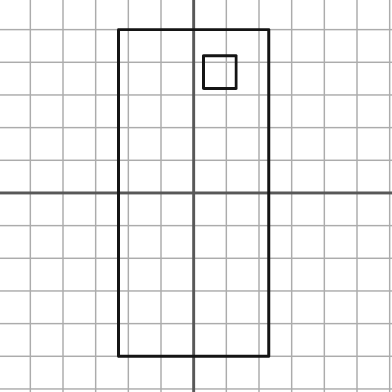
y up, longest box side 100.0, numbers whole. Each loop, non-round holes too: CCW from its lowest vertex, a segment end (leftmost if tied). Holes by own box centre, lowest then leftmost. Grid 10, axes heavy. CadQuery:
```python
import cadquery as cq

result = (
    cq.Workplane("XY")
    .moveTo(-23.0, -50.0)
    .lineTo(23.0, -50.0)
    .lineTo(23.0, 50.0)
    .lineTo(-23.0, 50.0)
    .close()
    .moveTo(3.0, 32.0)
    .lineTo(13.0, 32.0)
    .lineTo(13.0, 42.0)
    .lineTo(3.0, 42.0)
    .close()
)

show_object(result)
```